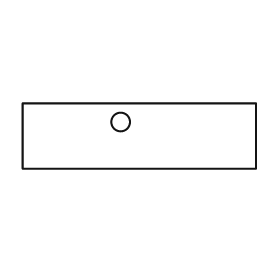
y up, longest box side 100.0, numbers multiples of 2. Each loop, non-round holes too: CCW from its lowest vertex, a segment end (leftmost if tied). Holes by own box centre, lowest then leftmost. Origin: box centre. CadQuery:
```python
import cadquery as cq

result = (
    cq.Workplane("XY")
    .moveTo(-50.0, -14.0)
    .lineTo(50.0, -14.0)
    .lineTo(50.0, 14.0)
    .lineTo(-50.0, 14.0)
    .close()
    .moveTo(-8.0, 6.0)
    .circle(4.0)
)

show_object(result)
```